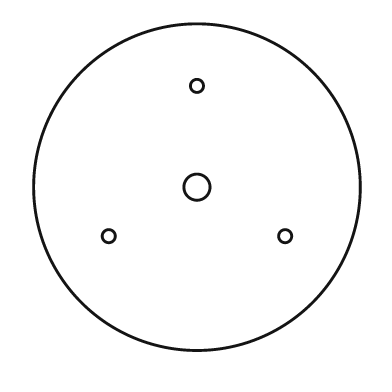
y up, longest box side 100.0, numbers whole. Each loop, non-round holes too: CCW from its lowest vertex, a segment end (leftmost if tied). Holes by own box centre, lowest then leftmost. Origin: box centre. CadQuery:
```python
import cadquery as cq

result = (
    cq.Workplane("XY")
    .moveTo(0.0, 0.0)
    .circle(50.0)
    .moveTo(-27.0, -15.0)
    .circle(2.0)
    .moveTo(27.0, -15.0)
    .circle(2.0)
    .moveTo(0.0, 0.0)
    .circle(4.0)
    .moveTo(0.0, 31.0)
    .circle(2.0)
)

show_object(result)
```